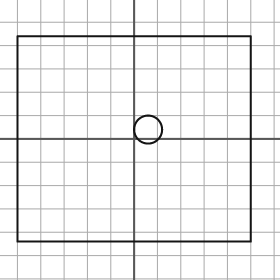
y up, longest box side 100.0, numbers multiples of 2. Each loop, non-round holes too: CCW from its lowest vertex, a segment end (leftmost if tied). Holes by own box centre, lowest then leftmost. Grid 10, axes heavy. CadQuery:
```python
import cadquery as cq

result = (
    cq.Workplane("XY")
    .moveTo(-50.0, -44.0)
    .lineTo(50.0, -44.0)
    .lineTo(50.0, 44.0)
    .lineTo(-50.0, 44.0)
    .close()
    .moveTo(6.0, 4.0)
    .circle(6.0)
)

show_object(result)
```